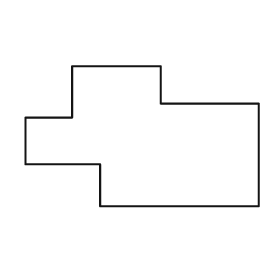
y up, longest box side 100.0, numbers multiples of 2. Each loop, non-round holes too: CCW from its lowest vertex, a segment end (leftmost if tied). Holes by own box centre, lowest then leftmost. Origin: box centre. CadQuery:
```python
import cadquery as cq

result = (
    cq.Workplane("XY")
    .moveTo(-18.0, -30.0)
    .lineTo(50.0, -30.0)
    .lineTo(50.0, 14.0)
    .lineTo(8.0, 14.0)
    .lineTo(8.0, 30.0)
    .lineTo(-30.0, 30.0)
    .lineTo(-30.0, 8.0)
    .lineTo(-50.0, 8.0)
    .lineTo(-50.0, -12.0)
    .lineTo(-18.0, -12.0)
    .close()
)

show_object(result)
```